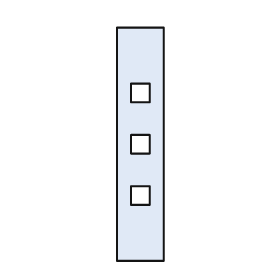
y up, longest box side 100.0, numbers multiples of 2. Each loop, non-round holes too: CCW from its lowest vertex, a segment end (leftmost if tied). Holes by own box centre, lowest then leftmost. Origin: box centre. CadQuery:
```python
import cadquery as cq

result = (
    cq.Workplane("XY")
    .moveTo(-10.0, -50.0)
    .lineTo(10.0, -50.0)
    .lineTo(10.0, 50.0)
    .lineTo(-10.0, 50.0)
    .close()
    .moveTo(-4.0, -26.0)
    .lineTo(4.0, -26.0)
    .lineTo(4.0, -18.0)
    .lineTo(-4.0, -18.0)
    .close()
    .moveTo(-4.0, -4.0)
    .lineTo(4.0, -4.0)
    .lineTo(4.0, 4.0)
    .lineTo(-4.0, 4.0)
    .close()
    .moveTo(-4.0, 18.0)
    .lineTo(4.0, 18.0)
    .lineTo(4.0, 26.0)
    .lineTo(-4.0, 26.0)
    .close()
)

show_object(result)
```